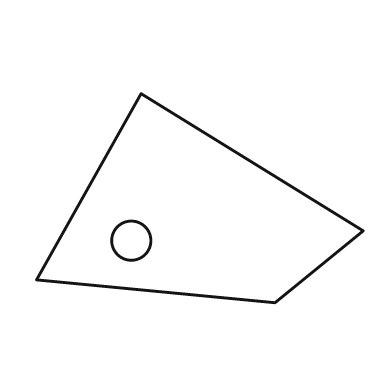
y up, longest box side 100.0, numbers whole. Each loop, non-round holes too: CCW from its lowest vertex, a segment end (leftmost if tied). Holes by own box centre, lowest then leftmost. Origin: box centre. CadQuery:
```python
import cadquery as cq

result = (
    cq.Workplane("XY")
    .moveTo(23.0, -32.0)
    .lineTo(50.0, -10.0)
    .lineTo(-18.0, 32.0)
    .lineTo(-50.0, -25.0)
    .close()
    .moveTo(-21.0, -13.0)
    .circle(6.0)
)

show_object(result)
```